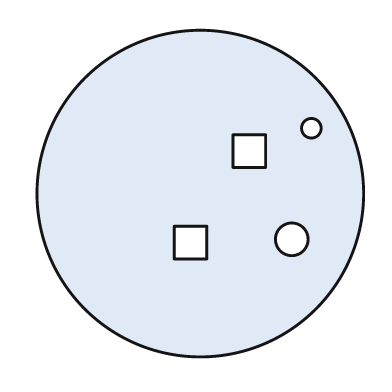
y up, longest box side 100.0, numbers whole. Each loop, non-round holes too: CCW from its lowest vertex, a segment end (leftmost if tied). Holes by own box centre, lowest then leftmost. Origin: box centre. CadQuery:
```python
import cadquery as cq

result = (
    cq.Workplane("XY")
    .moveTo(0.0, 0.0)
    .circle(50.0)
    .moveTo(-8.0, -20.0)
    .lineTo(2.0, -20.0)
    .lineTo(2.0, -10.0)
    .lineTo(-8.0, -10.0)
    .close()
    .moveTo(28.0, -14.0)
    .circle(5.0)
    .moveTo(10.0, 8.0)
    .lineTo(20.0, 8.0)
    .lineTo(20.0, 18.0)
    .lineTo(10.0, 18.0)
    .close()
    .moveTo(34.0, 20.0)
    .circle(3.0)
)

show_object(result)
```